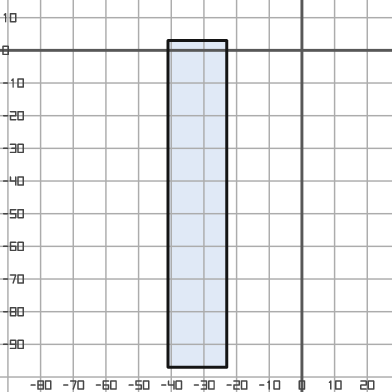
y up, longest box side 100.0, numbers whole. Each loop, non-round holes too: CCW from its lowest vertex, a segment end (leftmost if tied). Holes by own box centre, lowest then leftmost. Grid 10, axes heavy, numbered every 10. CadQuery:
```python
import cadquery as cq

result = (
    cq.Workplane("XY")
    .moveTo(-41.0, -97.0)
    .lineTo(-23.0, -97.0)
    .lineTo(-23.0, 3.0)
    .lineTo(-41.0, 3.0)
    .close()
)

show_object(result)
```